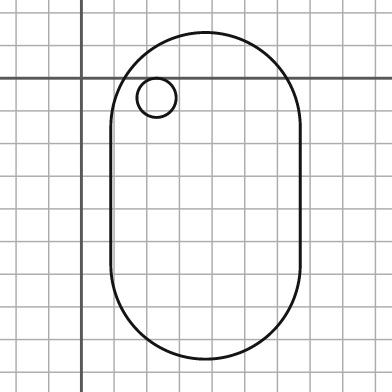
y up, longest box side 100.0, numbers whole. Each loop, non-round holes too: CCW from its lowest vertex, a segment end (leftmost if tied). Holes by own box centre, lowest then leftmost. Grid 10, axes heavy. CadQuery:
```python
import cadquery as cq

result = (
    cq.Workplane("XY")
    .moveTo(9.0, -57.0)
    .threePointArc((38.0, -86.0), (67.0, -57.0))
    .lineTo(67.0, -15.0)
    .threePointArc((38.0, 14.0), (9.0, -15.0))
    .close()
    .moveTo(23.0, -6.0)
    .circle(6.0)
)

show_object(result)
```